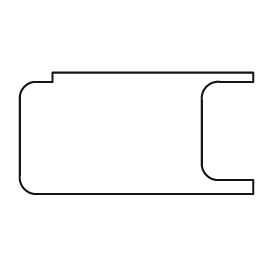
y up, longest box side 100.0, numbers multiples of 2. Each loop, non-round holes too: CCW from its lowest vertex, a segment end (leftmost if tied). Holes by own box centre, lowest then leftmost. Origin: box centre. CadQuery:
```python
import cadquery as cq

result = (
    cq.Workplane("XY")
    .moveTo(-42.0, -26.0)
    .lineTo(50.0, -26.0)
    .lineTo(50.0, -20.0)
    .lineTo(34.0, -20.0)
    .threePointArc((30.0, -18.0), (28.0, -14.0))
    .lineTo(28.0, 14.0)
    .threePointArc((30.0, 20.0), (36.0, 22.0))
    .lineTo(50.0, 22.0)
    .lineTo(50.0, 26.0)
    .lineTo(-36.0, 26.0)
    .lineTo(-36.0, 22.0)
    .lineTo(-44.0, 22.0)
    .threePointArc((-48.0, 20.0), (-50.0, 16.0))
    .lineTo(-50.0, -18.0)
    .threePointArc((-48.0, -24.0), (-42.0, -26.0))
    .close()
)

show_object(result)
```